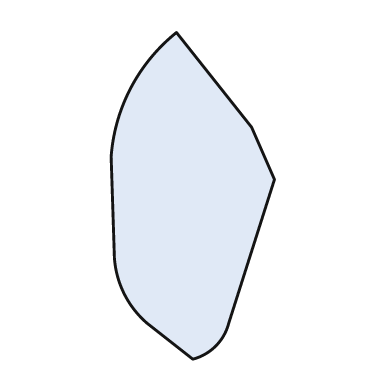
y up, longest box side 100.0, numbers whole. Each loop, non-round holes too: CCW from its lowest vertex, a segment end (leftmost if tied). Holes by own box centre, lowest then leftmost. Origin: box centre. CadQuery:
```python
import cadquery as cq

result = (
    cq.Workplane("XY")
    .moveTo(0.0, -50.0)
    .threePointArc((7.0, -46.0), (11.0, -39.0))
    .lineTo(25.0, 5.0)
    .lineTo(18.0, 21.0)
    .lineTo(-5.0, 50.0)
    .threePointArc((-19.0, 33.0), (-25.0, 12.0))
    .lineTo(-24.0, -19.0)
    .threePointArc((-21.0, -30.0), (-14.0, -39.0))
    .close()
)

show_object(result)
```